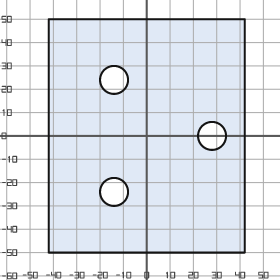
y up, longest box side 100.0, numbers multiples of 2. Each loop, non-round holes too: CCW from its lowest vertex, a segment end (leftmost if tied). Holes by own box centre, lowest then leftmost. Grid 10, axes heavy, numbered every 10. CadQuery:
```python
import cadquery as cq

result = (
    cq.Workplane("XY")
    .moveTo(-42.0, -50.0)
    .lineTo(42.0, -50.0)
    .lineTo(42.0, 50.0)
    .lineTo(-42.0, 50.0)
    .close()
    .moveTo(-14.0, -24.0)
    .circle(6.0)
    .moveTo(28.0, 0.0)
    .circle(6.0)
    .moveTo(-14.0, 24.0)
    .circle(6.0)
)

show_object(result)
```